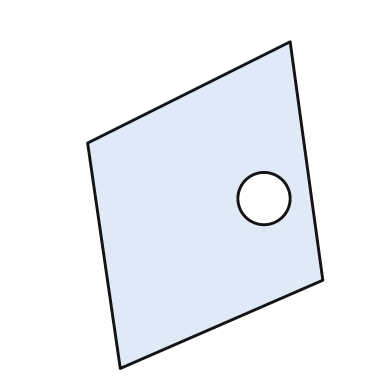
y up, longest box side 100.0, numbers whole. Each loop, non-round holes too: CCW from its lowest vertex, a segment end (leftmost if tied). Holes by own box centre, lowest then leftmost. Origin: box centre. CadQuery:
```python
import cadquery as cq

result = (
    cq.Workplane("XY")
    .moveTo(-26.0, -50.0)
    .lineTo(36.0, -23.0)
    .lineTo(26.0, 50.0)
    .lineTo(-36.0, 19.0)
    .close()
    .moveTo(18.0, 2.0)
    .circle(8.0)
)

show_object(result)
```